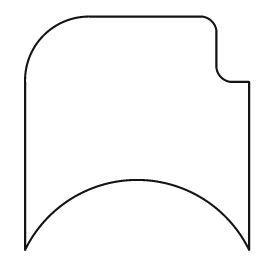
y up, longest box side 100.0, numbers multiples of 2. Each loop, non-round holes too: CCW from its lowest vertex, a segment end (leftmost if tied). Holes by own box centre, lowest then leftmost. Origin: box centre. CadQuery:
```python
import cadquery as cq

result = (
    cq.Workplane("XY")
    .moveTo(-48.0, -50.0)
    .threePointArc((0.0, -20.0), (48.0, -50.0))
    .lineTo(48.0, 22.0)
    .lineTo(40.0, 22.0)
    .threePointArc((36.0, 24.0), (34.0, 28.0))
    .lineTo(34.0, 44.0)
    .threePointArc((32.0, 48.0), (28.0, 50.0))
    .lineTo(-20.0, 50.0)
    .threePointArc((-40.0, 42.0), (-48.0, 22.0))
    .close()
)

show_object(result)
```